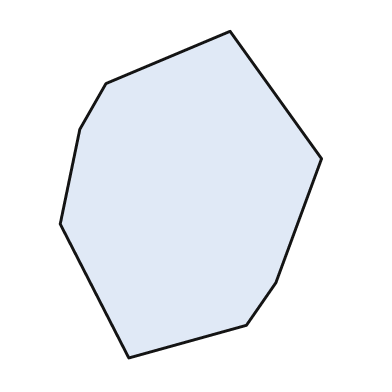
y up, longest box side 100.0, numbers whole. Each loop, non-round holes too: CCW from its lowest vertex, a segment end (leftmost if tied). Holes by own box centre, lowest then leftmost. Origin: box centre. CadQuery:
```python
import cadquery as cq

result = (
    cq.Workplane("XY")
    .moveTo(-19.0, -50.0)
    .lineTo(17.0, -40.0)
    .lineTo(26.0, -27.0)
    .lineTo(40.0, 11.0)
    .lineTo(12.0, 50.0)
    .lineTo(-26.0, 34.0)
    .lineTo(-34.0, 20.0)
    .lineTo(-40.0, -9.0)
    .close()
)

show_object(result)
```